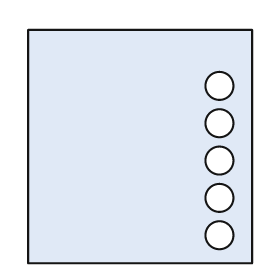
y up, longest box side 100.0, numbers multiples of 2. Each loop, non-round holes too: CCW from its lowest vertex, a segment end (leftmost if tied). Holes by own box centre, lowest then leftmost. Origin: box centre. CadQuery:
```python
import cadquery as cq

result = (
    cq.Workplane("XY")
    .moveTo(-48.0, -50.0)
    .lineTo(48.0, -50.0)
    .lineTo(48.0, 50.0)
    .lineTo(-48.0, 50.0)
    .close()
    .moveTo(34.0, -38.0)
    .circle(6.0)
    .moveTo(34.0, -22.0)
    .circle(6.0)
    .moveTo(34.0, -6.0)
    .circle(6.0)
    .moveTo(34.0, 10.0)
    .circle(6.0)
    .moveTo(34.0, 26.0)
    .circle(6.0)
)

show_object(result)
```